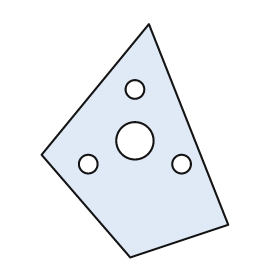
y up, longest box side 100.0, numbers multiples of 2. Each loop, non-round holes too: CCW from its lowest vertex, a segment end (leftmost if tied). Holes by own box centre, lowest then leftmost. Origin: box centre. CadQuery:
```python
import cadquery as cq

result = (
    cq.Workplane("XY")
    .moveTo(-2.0, -50.0)
    .lineTo(40.0, -36.0)
    .lineTo(6.0, 50.0)
    .lineTo(-40.0, -6.0)
    .close()
    .moveTo(-20.0, -10.0)
    .circle(4.0)
    .moveTo(20.0, -10.0)
    .circle(4.0)
    .moveTo(0.0, 0.0)
    .circle(8.0)
    .moveTo(0.0, 22.0)
    .circle(4.0)
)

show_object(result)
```